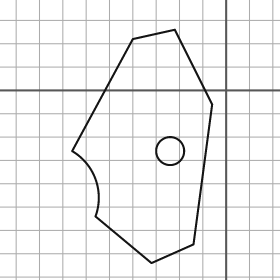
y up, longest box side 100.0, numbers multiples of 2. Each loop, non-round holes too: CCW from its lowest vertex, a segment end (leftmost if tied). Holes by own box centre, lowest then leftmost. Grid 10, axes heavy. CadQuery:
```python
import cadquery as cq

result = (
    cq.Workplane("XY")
    .moveTo(-32.0, -74.0)
    .lineTo(-14.0, -66.0)
    .lineTo(-6.0, -6.0)
    .lineTo(-22.0, 26.0)
    .lineTo(-40.0, 22.0)
    .lineTo(-66.0, -26.0)
    .threePointArc((-56.0, -38.0), (-56.0, -54.0))
    .close()
    .moveTo(-24.0, -26.0)
    .circle(6.0)
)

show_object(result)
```